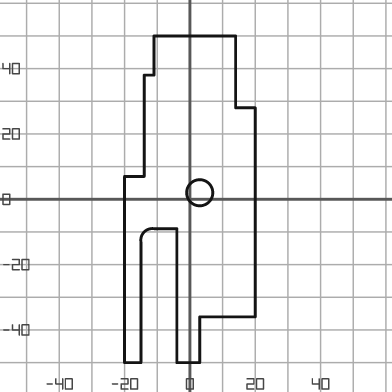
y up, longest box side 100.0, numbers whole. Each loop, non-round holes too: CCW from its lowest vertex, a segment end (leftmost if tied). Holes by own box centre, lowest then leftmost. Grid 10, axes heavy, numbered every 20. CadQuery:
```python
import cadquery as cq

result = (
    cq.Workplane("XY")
    .moveTo(-20.0, -50.0)
    .lineTo(-15.0, -50.0)
    .lineTo(-15.0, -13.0)
    .threePointArc((-14.0, -10.0), (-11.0, -9.0))
    .lineTo(-4.0, -9.0)
    .lineTo(-4.0, -50.0)
    .lineTo(3.0, -50.0)
    .lineTo(3.0, -36.0)
    .lineTo(20.0, -36.0)
    .lineTo(20.0, 28.0)
    .lineTo(14.0, 28.0)
    .lineTo(14.0, 50.0)
    .lineTo(-11.0, 50.0)
    .lineTo(-11.0, 38.0)
    .lineTo(-14.0, 38.0)
    .lineTo(-14.0, 7.0)
    .lineTo(-20.0, 7.0)
    .close()
    .moveTo(3.0, 2.0)
    .circle(4.0)
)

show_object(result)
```